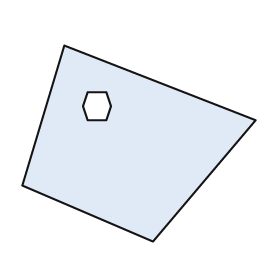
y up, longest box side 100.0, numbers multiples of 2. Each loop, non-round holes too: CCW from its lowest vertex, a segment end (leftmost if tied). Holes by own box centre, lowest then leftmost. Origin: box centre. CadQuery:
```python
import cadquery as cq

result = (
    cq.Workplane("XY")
    .moveTo(6.0, -42.0)
    .lineTo(50.0, 10.0)
    .lineTo(-32.0, 42.0)
    .lineTo(-50.0, -18.0)
    .close()
    .moveTo(-22.0, 10.0)
    .lineTo(-14.0, 10.0)
    .lineTo(-12.0, 16.0)
    .lineTo(-14.0, 22.0)
    .lineTo(-22.0, 22.0)
    .lineTo(-24.0, 16.0)
    .close()
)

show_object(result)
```